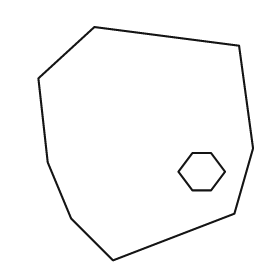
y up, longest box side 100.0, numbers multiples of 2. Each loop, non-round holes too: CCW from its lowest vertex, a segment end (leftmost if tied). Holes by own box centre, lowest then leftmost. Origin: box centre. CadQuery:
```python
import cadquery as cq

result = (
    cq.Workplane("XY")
    .moveTo(-14.0, -50.0)
    .lineTo(38.0, -30.0)
    .lineTo(46.0, -2.0)
    .lineTo(40.0, 42.0)
    .lineTo(-22.0, 50.0)
    .lineTo(-46.0, 28.0)
    .lineTo(-42.0, -8.0)
    .lineTo(-32.0, -32.0)
    .close()
    .moveTo(20.0, -20.0)
    .lineTo(28.0, -20.0)
    .lineTo(34.0, -12.0)
    .lineTo(28.0, -4.0)
    .lineTo(20.0, -4.0)
    .lineTo(14.0, -12.0)
    .close()
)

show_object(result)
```